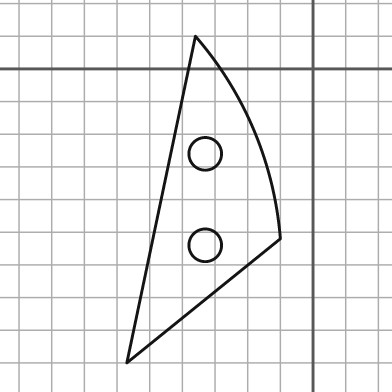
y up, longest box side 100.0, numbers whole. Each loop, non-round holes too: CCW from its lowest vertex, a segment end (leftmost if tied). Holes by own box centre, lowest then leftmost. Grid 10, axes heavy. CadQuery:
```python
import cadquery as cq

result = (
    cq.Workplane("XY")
    .moveTo(-57.0, -90.0)
    .lineTo(-10.0, -52.0)
    .threePointArc((-18.0, -19.0), (-36.0, 10.0))
    .close()
    .moveTo(-33.0, -54.0)
    .circle(5.0)
    .moveTo(-33.0, -26.0)
    .circle(5.0)
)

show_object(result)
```